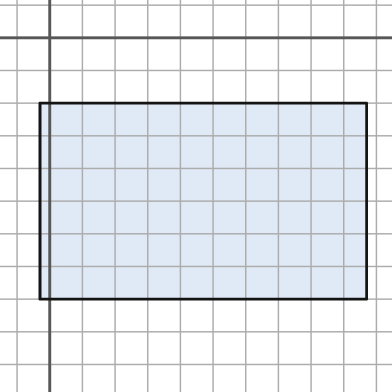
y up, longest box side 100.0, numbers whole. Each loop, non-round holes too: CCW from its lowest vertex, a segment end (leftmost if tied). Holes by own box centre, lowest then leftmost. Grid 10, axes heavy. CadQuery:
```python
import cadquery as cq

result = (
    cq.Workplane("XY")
    .moveTo(-3.0, -80.0)
    .lineTo(97.0, -80.0)
    .lineTo(97.0, -20.0)
    .lineTo(-3.0, -20.0)
    .close()
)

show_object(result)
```